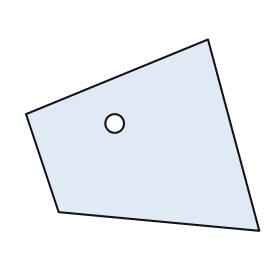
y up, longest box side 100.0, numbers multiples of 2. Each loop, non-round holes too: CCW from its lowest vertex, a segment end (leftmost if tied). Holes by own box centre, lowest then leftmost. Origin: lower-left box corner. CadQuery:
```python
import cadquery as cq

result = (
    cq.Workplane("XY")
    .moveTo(100.0, 0.0)
    .lineTo(78.0, 82.0)
    .lineTo(0.0, 50.0)
    .lineTo(14.0, 8.0)
    .close()
    .moveTo(38.0, 46.0)
    .circle(4.0)
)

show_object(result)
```